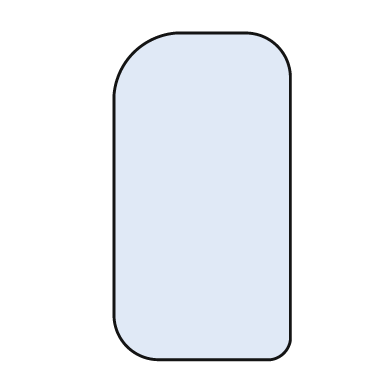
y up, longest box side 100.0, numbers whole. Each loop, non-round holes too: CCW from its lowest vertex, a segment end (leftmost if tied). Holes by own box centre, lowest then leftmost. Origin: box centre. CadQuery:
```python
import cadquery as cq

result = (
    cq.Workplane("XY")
    .moveTo(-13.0, -50.0)
    .lineTo(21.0, -50.0)
    .threePointArc((25.0, -48.0), (27.0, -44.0))
    .lineTo(27.0, 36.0)
    .threePointArc((23.0, 46.0), (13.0, 50.0))
    .lineTo(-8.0, 50.0)
    .threePointArc((-21.0, 44.0), (-27.0, 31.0))
    .lineTo(-27.0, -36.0)
    .threePointArc((-23.0, -46.0), (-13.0, -50.0))
    .close()
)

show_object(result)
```